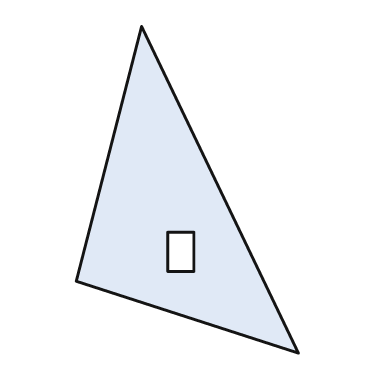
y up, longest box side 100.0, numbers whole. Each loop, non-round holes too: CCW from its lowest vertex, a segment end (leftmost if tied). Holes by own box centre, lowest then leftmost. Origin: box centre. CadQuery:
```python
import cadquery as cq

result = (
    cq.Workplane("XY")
    .moveTo(34.0, -50.0)
    .lineTo(-14.0, 50.0)
    .lineTo(-34.0, -28.0)
    .close()
    .moveTo(-6.0, -25.0)
    .lineTo(2.0, -25.0)
    .lineTo(2.0, -13.0)
    .lineTo(-6.0, -13.0)
    .close()
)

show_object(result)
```